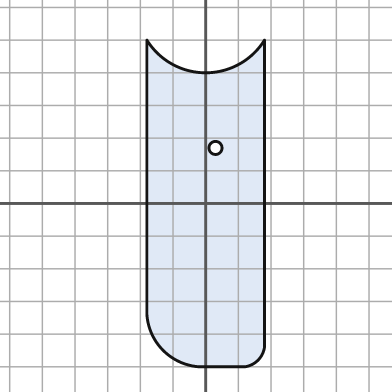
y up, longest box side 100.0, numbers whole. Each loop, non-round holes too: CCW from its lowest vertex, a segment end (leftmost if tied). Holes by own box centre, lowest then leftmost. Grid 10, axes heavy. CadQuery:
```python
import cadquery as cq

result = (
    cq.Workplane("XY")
    .moveTo(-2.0, -50.0)
    .lineTo(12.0, -50.0)
    .threePointArc((16.0, -48.0), (18.0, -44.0))
    .lineTo(18.0, 50.0)
    .threePointArc((0.0, 40.0), (-18.0, 50.0))
    .lineTo(-18.0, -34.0)
    .threePointArc((-13.0, -45.0), (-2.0, -50.0))
    .close()
    .moveTo(3.0, 17.0)
    .circle(2.0)
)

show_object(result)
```